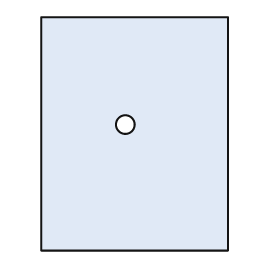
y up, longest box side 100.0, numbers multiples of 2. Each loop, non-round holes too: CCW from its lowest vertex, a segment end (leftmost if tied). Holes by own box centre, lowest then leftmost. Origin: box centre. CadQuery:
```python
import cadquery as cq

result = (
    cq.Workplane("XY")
    .moveTo(-40.0, -50.0)
    .lineTo(40.0, -50.0)
    .lineTo(40.0, 50.0)
    .lineTo(-40.0, 50.0)
    .close()
    .moveTo(-4.0, 4.0)
    .circle(4.0)
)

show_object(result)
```